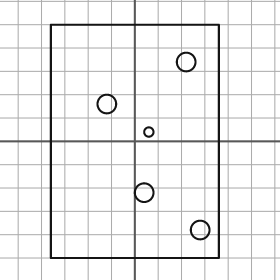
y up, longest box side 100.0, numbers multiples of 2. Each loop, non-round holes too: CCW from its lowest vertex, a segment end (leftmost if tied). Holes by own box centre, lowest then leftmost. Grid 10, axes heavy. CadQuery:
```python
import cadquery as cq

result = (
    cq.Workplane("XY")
    .moveTo(-36.0, -50.0)
    .lineTo(36.0, -50.0)
    .lineTo(36.0, 50.0)
    .lineTo(-36.0, 50.0)
    .close()
    .moveTo(28.0, -38.0)
    .circle(4.0)
    .moveTo(4.0, -22.0)
    .circle(4.0)
    .moveTo(6.0, 4.0)
    .circle(2.0)
    .moveTo(-12.0, 16.0)
    .circle(4.0)
    .moveTo(22.0, 34.0)
    .circle(4.0)
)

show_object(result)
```